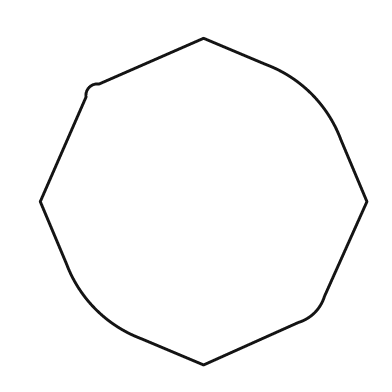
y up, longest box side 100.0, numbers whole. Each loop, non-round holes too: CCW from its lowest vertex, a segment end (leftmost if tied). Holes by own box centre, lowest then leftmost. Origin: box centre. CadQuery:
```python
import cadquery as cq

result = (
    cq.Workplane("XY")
    .moveTo(0.0, -50.0)
    .lineTo(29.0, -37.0)
    .threePointArc((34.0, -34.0), (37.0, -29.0))
    .lineTo(50.0, 0.0)
    .lineTo(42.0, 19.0)
    .threePointArc((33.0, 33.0), (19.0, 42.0))
    .lineTo(0.0, 50.0)
    .lineTo(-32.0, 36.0)
    .threePointArc((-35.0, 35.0), (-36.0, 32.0))
    .lineTo(-50.0, 0.0)
    .lineTo(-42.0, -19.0)
    .threePointArc((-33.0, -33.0), (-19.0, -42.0))
    .close()
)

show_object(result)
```